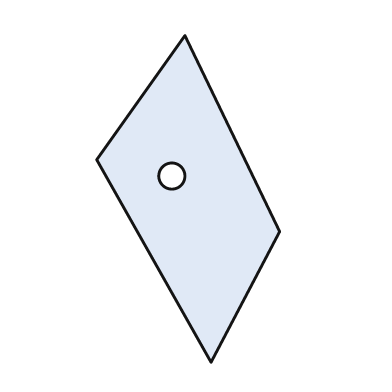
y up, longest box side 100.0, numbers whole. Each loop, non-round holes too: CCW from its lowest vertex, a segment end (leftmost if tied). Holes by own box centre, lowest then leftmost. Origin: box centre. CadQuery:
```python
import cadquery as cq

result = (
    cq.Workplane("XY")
    .moveTo(7.0, -50.0)
    .lineTo(28.0, -10.0)
    .lineTo(-1.0, 50.0)
    .lineTo(-28.0, 12.0)
    .close()
    .moveTo(-5.0, 7.0)
    .circle(4.0)
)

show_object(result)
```